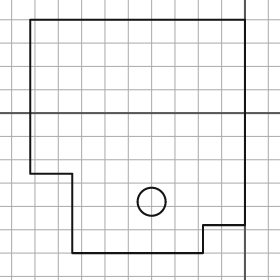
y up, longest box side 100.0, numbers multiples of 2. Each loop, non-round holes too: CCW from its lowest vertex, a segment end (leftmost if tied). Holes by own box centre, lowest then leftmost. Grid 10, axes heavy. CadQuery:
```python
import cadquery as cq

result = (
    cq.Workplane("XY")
    .moveTo(-74.0, -60.0)
    .lineTo(-18.0, -60.0)
    .lineTo(-18.0, -48.0)
    .lineTo(0.0, -48.0)
    .lineTo(0.0, 40.0)
    .lineTo(-92.0, 40.0)
    .lineTo(-92.0, -26.0)
    .lineTo(-74.0, -26.0)
    .close()
    .moveTo(-40.0, -38.0)
    .circle(6.0)
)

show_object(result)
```